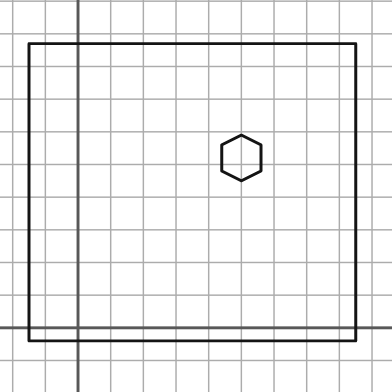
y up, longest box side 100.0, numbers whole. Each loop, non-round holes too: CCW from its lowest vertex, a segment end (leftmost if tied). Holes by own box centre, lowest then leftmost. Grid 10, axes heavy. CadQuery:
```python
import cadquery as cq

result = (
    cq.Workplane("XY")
    .moveTo(-15.0, -4.0)
    .lineTo(85.0, -4.0)
    .lineTo(85.0, 87.0)
    .lineTo(-15.0, 87.0)
    .close()
    .moveTo(50.0, 45.0)
    .lineTo(56.0, 48.0)
    .lineTo(56.0, 56.0)
    .lineTo(50.0, 59.0)
    .lineTo(44.0, 56.0)
    .lineTo(44.0, 48.0)
    .close()
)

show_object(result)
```